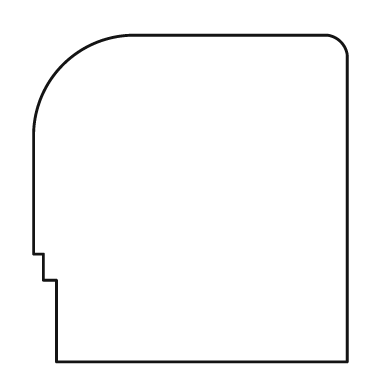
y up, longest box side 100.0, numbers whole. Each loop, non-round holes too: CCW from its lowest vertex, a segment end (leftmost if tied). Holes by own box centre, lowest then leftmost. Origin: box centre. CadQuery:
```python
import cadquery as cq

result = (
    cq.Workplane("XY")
    .moveTo(-41.0, -50.0)
    .lineTo(48.0, -50.0)
    .lineTo(48.0, 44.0)
    .threePointArc((46.0, 48.0), (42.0, 50.0))
    .lineTo(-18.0, 50.0)
    .threePointArc((-39.0, 41.0), (-48.0, 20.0))
    .lineTo(-48.0, -17.0)
    .lineTo(-45.0, -17.0)
    .lineTo(-45.0, -25.0)
    .lineTo(-41.0, -25.0)
    .close()
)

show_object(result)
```